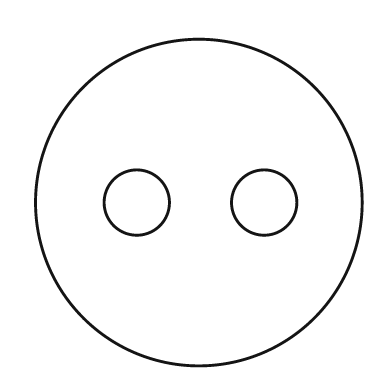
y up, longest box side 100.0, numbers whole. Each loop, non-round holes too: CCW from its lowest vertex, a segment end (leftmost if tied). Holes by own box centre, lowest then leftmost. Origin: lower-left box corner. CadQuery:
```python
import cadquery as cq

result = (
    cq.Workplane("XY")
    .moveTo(50.0, 50.0)
    .circle(50.0)
    .moveTo(31.0, 50.0)
    .circle(10.0)
    .moveTo(70.0, 50.0)
    .circle(10.0)
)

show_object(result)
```